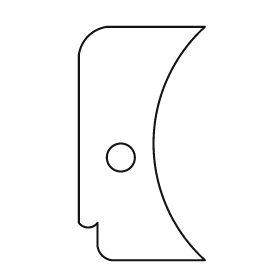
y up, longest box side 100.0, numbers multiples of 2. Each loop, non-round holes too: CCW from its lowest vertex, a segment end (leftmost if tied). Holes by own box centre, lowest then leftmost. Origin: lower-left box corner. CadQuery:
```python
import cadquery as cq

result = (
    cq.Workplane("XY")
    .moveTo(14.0, 0.0)
    .lineTo(54.0, 0.0)
    .threePointArc((32.0, 50.0), (54.0, 100.0))
    .lineTo(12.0, 100.0)
    .threePointArc((4.0, 96.0), (0.0, 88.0))
    .lineTo(0.0, 16.0)
    .threePointArc((4.0, 14.0), (8.0, 16.0))
    .lineTo(8.0, 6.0)
    .threePointArc((10.0, 2.0), (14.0, 0.0))
    .close()
    .moveTo(18.0, 44.0)
    .circle(6.0)
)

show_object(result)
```